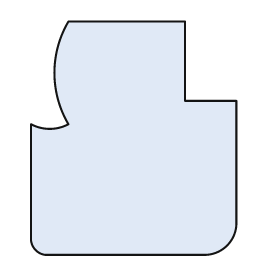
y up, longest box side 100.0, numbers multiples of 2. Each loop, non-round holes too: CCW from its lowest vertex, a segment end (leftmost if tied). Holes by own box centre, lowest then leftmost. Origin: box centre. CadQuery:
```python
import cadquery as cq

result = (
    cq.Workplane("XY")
    .moveTo(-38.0, -50.0)
    .lineTo(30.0, -50.0)
    .threePointArc((40.0, -46.0), (44.0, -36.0))
    .lineTo(44.0, 16.0)
    .lineTo(22.0, 16.0)
    .lineTo(22.0, 50.0)
    .lineTo(-28.0, 50.0)
    .threePointArc((-34.0, 28.0), (-28.0, 6.0))
    .threePointArc((-36.0, 4.0), (-44.0, 6.0))
    .lineTo(-44.0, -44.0)
    .threePointArc((-42.0, -48.0), (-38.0, -50.0))
    .close()
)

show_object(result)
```